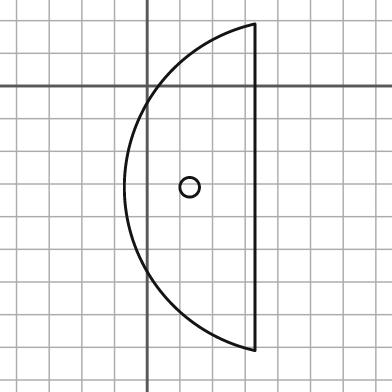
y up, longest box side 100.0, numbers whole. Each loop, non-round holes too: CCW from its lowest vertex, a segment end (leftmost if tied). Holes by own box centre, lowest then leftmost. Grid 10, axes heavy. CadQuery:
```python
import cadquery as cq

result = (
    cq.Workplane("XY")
    .moveTo(33.0, -81.0)
    .lineTo(33.0, 19.0)
    .threePointArc((-7.0, -31.0), (33.0, -81.0))
    .close()
    .moveTo(13.0, -31.0)
    .circle(3.0)
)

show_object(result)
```